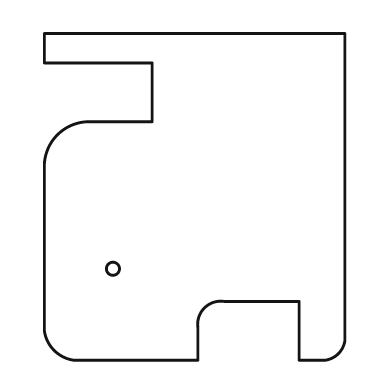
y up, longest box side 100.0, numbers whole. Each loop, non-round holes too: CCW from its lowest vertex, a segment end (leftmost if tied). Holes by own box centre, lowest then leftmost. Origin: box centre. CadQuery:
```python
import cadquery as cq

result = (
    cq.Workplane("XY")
    .moveTo(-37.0, -50.0)
    .lineTo(1.0, -50.0)
    .lineTo(1.0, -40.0)
    .threePointArc((3.0, -34.0), (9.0, -32.0))
    .lineTo(32.0, -32.0)
    .lineTo(32.0, -50.0)
    .lineTo(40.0, -50.0)
    .threePointArc((44.0, -48.0), (46.0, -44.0))
    .lineTo(46.0, 50.0)
    .lineTo(-46.0, 50.0)
    .lineTo(-46.0, 41.0)
    .lineTo(-13.0, 41.0)
    .lineTo(-13.0, 23.0)
    .lineTo(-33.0, 23.0)
    .threePointArc((-42.0, 19.0), (-46.0, 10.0))
    .lineTo(-46.0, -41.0)
    .threePointArc((-43.0, -47.0), (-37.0, -50.0))
    .close()
    .moveTo(-25.0, -22.0)
    .circle(2.0)
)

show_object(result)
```